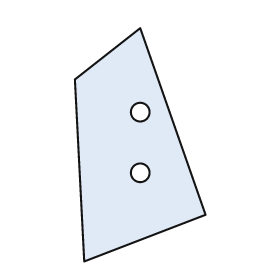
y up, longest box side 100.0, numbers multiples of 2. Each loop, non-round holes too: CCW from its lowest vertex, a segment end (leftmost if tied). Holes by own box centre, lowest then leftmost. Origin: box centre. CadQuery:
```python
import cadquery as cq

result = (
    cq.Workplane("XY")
    .moveTo(-24.0, -50.0)
    .lineTo(28.0, -30.0)
    .lineTo(0.0, 50.0)
    .lineTo(-28.0, 28.0)
    .close()
    .moveTo(0.0, -12.0)
    .circle(4.0)
    .moveTo(0.0, 14.0)
    .circle(4.0)
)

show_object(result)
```